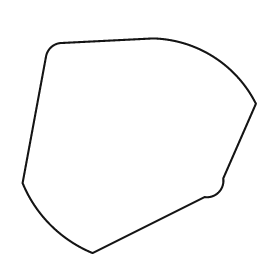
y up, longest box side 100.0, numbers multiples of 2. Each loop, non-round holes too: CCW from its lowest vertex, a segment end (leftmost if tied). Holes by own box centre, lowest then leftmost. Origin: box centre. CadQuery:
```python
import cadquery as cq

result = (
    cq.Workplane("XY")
    .moveTo(-20.0, -46.0)
    .lineTo(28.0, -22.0)
    .threePointArc((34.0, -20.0), (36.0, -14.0))
    .lineTo(50.0, 18.0)
    .threePointArc((32.0, 38.0), (6.0, 46.0))
    .lineTo(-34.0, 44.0)
    .threePointArc((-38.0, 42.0), (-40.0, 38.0))
    .lineTo(-50.0, -16.0)
    .threePointArc((-38.0, -34.0), (-20.0, -46.0))
    .close()
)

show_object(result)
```